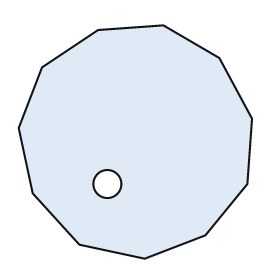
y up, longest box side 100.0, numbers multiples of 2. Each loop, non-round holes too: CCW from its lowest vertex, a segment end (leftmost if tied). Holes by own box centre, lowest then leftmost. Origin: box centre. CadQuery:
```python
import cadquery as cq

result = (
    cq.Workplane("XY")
    .moveTo(4.0, -50.0)
    .lineTo(30.0, -40.0)
    .lineTo(48.0, -18.0)
    .lineTo(50.0, 10.0)
    .lineTo(36.0, 36.0)
    .lineTo(12.0, 50.0)
    .lineTo(-16.0, 48.0)
    .lineTo(-40.0, 32.0)
    .lineTo(-50.0, 6.0)
    .lineTo(-44.0, -22.0)
    .lineTo(-24.0, -44.0)
    .close()
    .moveTo(-12.0, -18.0)
    .circle(6.0)
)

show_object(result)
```